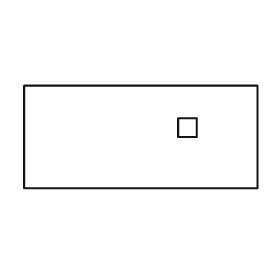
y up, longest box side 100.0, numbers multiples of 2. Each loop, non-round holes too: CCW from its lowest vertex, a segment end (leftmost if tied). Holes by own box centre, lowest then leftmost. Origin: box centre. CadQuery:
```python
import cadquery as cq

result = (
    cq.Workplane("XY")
    .moveTo(-50.0, -22.0)
    .lineTo(50.0, -22.0)
    .lineTo(50.0, 22.0)
    .lineTo(-50.0, 22.0)
    .close()
    .moveTo(16.0, 0.0)
    .lineTo(24.0, 0.0)
    .lineTo(24.0, 8.0)
    .lineTo(16.0, 8.0)
    .close()
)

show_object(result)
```